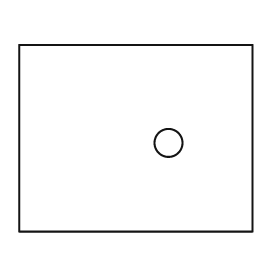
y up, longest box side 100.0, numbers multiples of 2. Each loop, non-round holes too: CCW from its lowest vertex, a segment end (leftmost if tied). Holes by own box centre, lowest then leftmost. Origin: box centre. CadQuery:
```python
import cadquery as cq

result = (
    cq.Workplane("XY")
    .moveTo(-50.0, -40.0)
    .lineTo(50.0, -40.0)
    .lineTo(50.0, 40.0)
    .lineTo(-50.0, 40.0)
    .close()
    .moveTo(14.0, -2.0)
    .circle(6.0)
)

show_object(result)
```